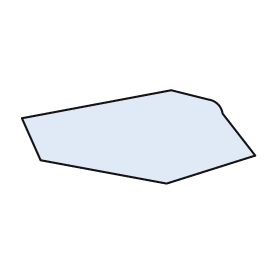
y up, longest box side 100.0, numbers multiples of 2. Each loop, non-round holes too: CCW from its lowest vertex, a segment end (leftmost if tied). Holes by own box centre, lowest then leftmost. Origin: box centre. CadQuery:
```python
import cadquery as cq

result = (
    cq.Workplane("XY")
    .moveTo(12.0, -20.0)
    .lineTo(50.0, -8.0)
    .lineTo(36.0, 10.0)
    .threePointArc((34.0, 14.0), (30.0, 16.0))
    .lineTo(14.0, 20.0)
    .lineTo(-50.0, 8.0)
    .lineTo(-42.0, -10.0)
    .close()
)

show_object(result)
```